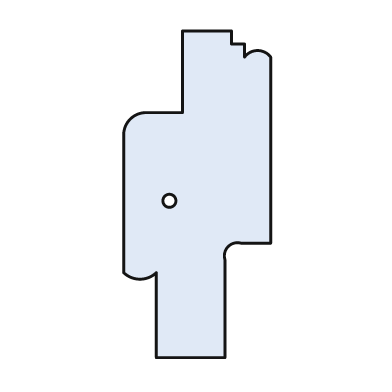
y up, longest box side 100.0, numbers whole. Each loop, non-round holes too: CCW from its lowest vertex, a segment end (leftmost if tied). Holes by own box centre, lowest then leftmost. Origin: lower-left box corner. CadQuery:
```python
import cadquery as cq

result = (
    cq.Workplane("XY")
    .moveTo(10.0, 0.0)
    .lineTo(31.0, 0.0)
    .lineTo(31.0, 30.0)
    .threePointArc((32.0, 34.0), (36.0, 35.0))
    .lineTo(45.0, 35.0)
    .lineTo(45.0, 92.0)
    .threePointArc((41.0, 94.0), (37.0, 92.0))
    .lineTo(37.0, 96.0)
    .lineTo(33.0, 96.0)
    .lineTo(33.0, 100.0)
    .lineTo(18.0, 100.0)
    .lineTo(18.0, 75.0)
    .lineTo(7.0, 75.0)
    .threePointArc((2.0, 73.0), (0.0, 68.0))
    .lineTo(0.0, 26.0)
    .threePointArc((5.0, 24.0), (10.0, 26.0))
    .close()
    .moveTo(14.0, 48.0)
    .circle(2.0)
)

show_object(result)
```